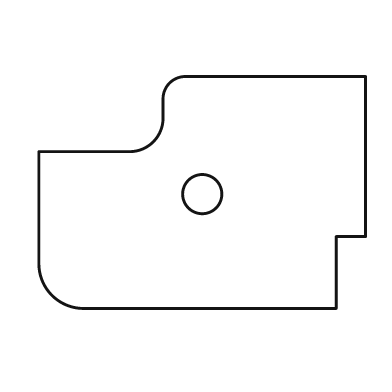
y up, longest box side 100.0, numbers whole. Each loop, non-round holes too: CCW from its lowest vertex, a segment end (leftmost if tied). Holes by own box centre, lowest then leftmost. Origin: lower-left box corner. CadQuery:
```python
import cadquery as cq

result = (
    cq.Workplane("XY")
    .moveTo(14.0, 0.0)
    .lineTo(91.0, 0.0)
    .lineTo(91.0, 22.0)
    .lineTo(100.0, 22.0)
    .lineTo(100.0, 71.0)
    .lineTo(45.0, 71.0)
    .threePointArc((40.0, 69.0), (38.0, 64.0))
    .lineTo(38.0, 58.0)
    .threePointArc((35.0, 51.0), (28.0, 48.0))
    .lineTo(0.0, 48.0)
    .lineTo(0.0, 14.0)
    .threePointArc((4.0, 4.0), (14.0, 0.0))
    .close()
    .moveTo(50.0, 35.0)
    .circle(6.0)
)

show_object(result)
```